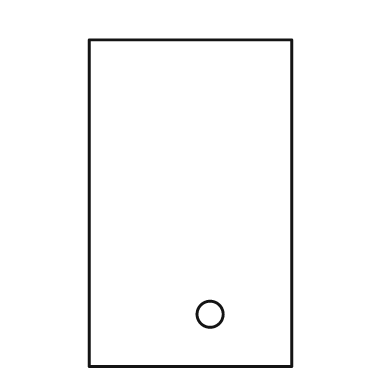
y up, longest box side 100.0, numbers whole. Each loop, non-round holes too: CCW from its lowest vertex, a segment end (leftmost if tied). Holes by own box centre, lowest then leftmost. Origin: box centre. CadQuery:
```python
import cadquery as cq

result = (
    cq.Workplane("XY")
    .moveTo(-31.0, -50.0)
    .lineTo(31.0, -50.0)
    .lineTo(31.0, 50.0)
    .lineTo(-31.0, 50.0)
    .close()
    .moveTo(6.0, -34.0)
    .circle(4.0)
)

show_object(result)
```